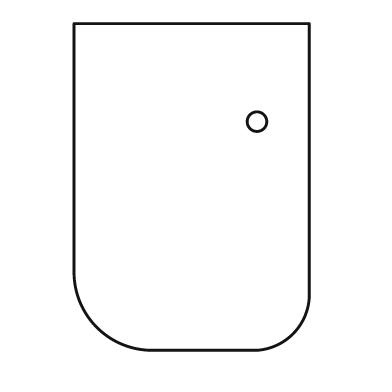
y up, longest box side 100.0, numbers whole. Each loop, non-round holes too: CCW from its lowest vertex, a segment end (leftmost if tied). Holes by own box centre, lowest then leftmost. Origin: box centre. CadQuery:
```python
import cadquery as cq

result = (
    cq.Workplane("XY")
    .moveTo(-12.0, -50.0)
    .lineTo(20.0, -50.0)
    .threePointArc((31.0, -45.0), (36.0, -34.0))
    .lineTo(36.0, 50.0)
    .lineTo(-36.0, 50.0)
    .lineTo(-36.0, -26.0)
    .threePointArc((-29.0, -43.0), (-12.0, -50.0))
    .close()
    .moveTo(20.0, 20.0)
    .circle(3.0)
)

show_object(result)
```